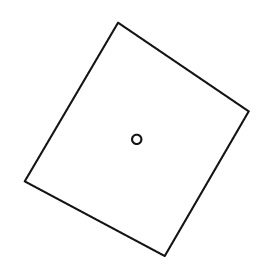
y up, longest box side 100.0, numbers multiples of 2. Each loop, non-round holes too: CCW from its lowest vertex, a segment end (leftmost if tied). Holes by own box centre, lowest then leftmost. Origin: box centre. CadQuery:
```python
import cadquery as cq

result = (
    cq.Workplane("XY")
    .moveTo(12.0, -50.0)
    .lineTo(48.0, 12.0)
    .lineTo(-8.0, 50.0)
    .lineTo(-48.0, -18.0)
    .close()
    .moveTo(0.0, 0.0)
    .circle(2.0)
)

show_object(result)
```